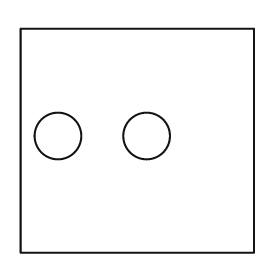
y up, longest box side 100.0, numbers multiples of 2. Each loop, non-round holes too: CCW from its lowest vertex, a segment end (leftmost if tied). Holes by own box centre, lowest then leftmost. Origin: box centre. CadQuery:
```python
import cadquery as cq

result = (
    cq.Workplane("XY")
    .moveTo(-50.0, -48.0)
    .lineTo(50.0, -48.0)
    .lineTo(50.0, 48.0)
    .lineTo(-50.0, 48.0)
    .close()
    .moveTo(-34.0, 2.0)
    .circle(10.0)
    .moveTo(4.0, 2.0)
    .circle(10.0)
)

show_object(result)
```